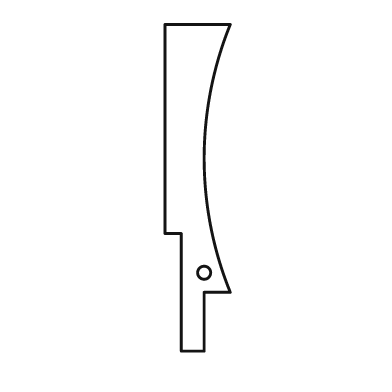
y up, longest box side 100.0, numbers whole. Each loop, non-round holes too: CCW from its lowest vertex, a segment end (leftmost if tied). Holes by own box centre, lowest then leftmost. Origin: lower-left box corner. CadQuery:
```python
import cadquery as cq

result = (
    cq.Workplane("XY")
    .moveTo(5.0, 0.0)
    .lineTo(12.0, 0.0)
    .lineTo(12.0, 18.0)
    .lineTo(20.0, 18.0)
    .threePointArc((12.0, 59.0), (20.0, 100.0))
    .lineTo(0.0, 100.0)
    .lineTo(0.0, 36.0)
    .lineTo(5.0, 36.0)
    .close()
    .moveTo(12.0, 24.0)
    .circle(2.0)
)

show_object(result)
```